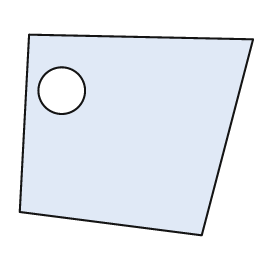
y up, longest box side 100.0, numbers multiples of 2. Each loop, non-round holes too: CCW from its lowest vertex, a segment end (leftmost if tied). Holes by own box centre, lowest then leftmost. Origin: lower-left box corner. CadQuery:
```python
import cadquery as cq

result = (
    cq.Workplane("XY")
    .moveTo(78.0, 0.0)
    .lineTo(100.0, 84.0)
    .lineTo(4.0, 86.0)
    .lineTo(0.0, 10.0)
    .close()
    .moveTo(18.0, 62.0)
    .circle(10.0)
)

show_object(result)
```